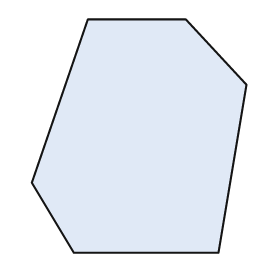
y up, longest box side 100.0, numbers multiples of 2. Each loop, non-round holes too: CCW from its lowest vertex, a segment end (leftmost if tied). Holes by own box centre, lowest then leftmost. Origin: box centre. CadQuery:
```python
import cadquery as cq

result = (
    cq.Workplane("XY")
    .moveTo(-28.0, -50.0)
    .lineTo(34.0, -50.0)
    .lineTo(46.0, 22.0)
    .lineTo(20.0, 50.0)
    .lineTo(-22.0, 50.0)
    .lineTo(-46.0, -20.0)
    .close()
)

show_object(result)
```